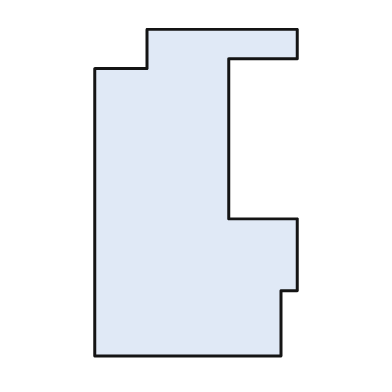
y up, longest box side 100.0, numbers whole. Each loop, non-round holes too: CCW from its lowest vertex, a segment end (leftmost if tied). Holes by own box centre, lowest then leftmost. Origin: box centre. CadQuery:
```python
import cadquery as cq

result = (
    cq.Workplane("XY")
    .moveTo(-31.0, -50.0)
    .lineTo(26.0, -50.0)
    .lineTo(26.0, -30.0)
    .lineTo(31.0, -30.0)
    .lineTo(31.0, -8.0)
    .lineTo(10.0, -8.0)
    .lineTo(10.0, 41.0)
    .lineTo(31.0, 41.0)
    .lineTo(31.0, 50.0)
    .lineTo(-15.0, 50.0)
    .lineTo(-15.0, 38.0)
    .lineTo(-31.0, 38.0)
    .close()
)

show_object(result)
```